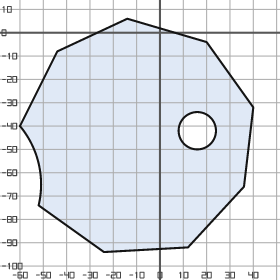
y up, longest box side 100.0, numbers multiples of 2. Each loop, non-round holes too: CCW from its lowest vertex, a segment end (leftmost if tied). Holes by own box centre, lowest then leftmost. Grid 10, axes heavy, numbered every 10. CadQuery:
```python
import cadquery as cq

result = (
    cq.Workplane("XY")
    .moveTo(-24.0, -94.0)
    .lineTo(12.0, -92.0)
    .lineTo(36.0, -66.0)
    .lineTo(40.0, -32.0)
    .lineTo(20.0, -4.0)
    .lineTo(-14.0, 6.0)
    .lineTo(-44.0, -8.0)
    .lineTo(-60.0, -40.0)
    .threePointArc((-52.0, -56.0), (-52.0, -74.0))
    .close()
    .moveTo(16.0, -42.0)
    .circle(8.0)
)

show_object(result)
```